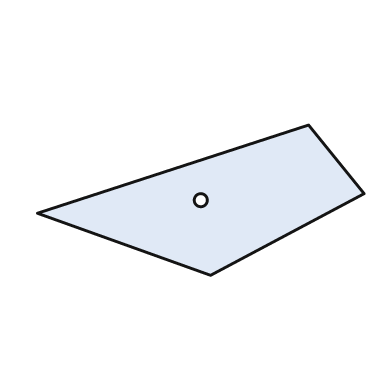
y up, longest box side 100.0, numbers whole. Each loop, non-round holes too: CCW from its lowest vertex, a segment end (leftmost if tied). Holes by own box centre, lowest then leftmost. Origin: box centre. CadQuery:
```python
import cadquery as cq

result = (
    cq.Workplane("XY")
    .moveTo(3.0, -23.0)
    .lineTo(50.0, 2.0)
    .lineTo(33.0, 23.0)
    .lineTo(-50.0, -4.0)
    .close()
    .moveTo(0.0, 0.0)
    .circle(2.0)
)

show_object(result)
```